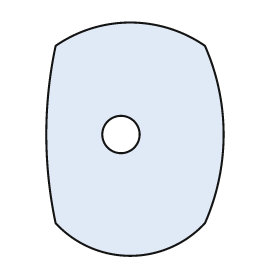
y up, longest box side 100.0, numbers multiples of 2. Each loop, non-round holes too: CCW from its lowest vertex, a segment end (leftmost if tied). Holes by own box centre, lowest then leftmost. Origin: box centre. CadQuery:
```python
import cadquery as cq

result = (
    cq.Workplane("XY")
    .moveTo(-34.0, -36.0)
    .threePointArc((-2.0, -50.0), (30.0, -36.0))
    .threePointArc((38.0, 2.0), (30.0, 40.0))
    .threePointArc((-2.0, 50.0), (-34.0, 40.0))
    .threePointArc((-38.0, 2.0), (-34.0, -36.0))
    .close()
    .moveTo(-6.0, 2.0)
    .circle(8.0)
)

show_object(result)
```